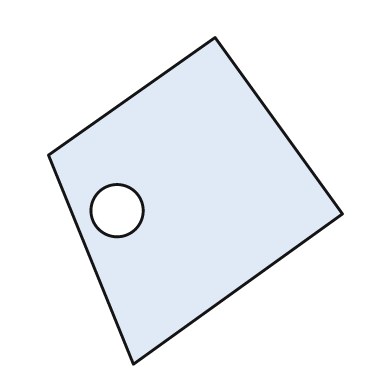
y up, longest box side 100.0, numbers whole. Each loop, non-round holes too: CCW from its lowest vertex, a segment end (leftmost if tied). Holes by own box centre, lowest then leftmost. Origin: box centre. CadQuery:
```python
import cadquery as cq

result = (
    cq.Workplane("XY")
    .moveTo(-19.0, -50.0)
    .lineTo(45.0, -4.0)
    .lineTo(6.0, 50.0)
    .lineTo(-45.0, 14.0)
    .close()
    .moveTo(-24.0, -3.0)
    .circle(8.0)
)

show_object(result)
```